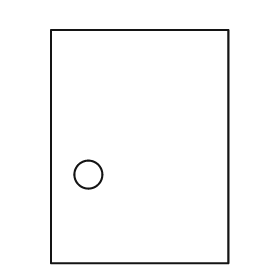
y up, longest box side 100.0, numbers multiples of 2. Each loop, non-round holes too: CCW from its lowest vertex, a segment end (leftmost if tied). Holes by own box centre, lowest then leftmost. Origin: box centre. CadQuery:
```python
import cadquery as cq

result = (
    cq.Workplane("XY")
    .moveTo(-38.0, -50.0)
    .lineTo(38.0, -50.0)
    .lineTo(38.0, 50.0)
    .lineTo(-38.0, 50.0)
    .close()
    .moveTo(-22.0, -12.0)
    .circle(6.0)
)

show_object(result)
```